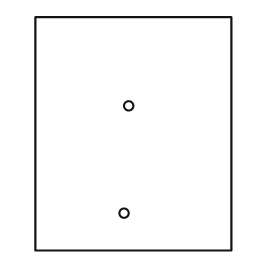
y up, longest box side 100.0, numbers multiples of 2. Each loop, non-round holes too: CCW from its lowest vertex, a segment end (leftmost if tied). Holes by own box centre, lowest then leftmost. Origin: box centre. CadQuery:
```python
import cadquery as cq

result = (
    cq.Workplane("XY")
    .moveTo(-42.0, -50.0)
    .lineTo(42.0, -50.0)
    .lineTo(42.0, 50.0)
    .lineTo(-42.0, 50.0)
    .close()
    .moveTo(-4.0, -34.0)
    .circle(2.0)
    .moveTo(-2.0, 12.0)
    .circle(2.0)
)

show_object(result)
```